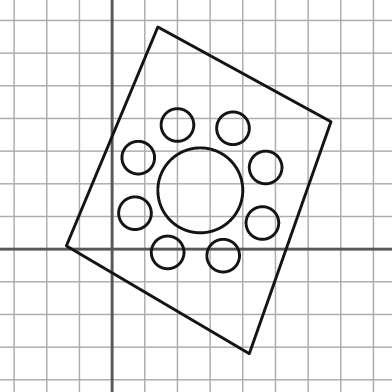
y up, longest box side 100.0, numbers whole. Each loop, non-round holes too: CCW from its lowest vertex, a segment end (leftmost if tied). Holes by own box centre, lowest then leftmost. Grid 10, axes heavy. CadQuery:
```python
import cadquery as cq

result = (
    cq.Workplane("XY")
    .moveTo(42.0, -32.0)
    .lineTo(67.0, 39.0)
    .lineTo(14.0, 68.0)
    .lineTo(-14.0, 1.0)
    .close()
    .moveTo(34.0, -2.0)
    .circle(5.0)
    .moveTo(17.0, -1.0)
    .circle(5.0)
    .moveTo(46.0, 8.0)
    .circle(5.0)
    .moveTo(7.0, 11.0)
    .circle(5.0)
    .moveTo(27.0, 18.0)
    .circle(13.0)
    .moveTo(47.0, 25.0)
    .circle(5.0)
    .moveTo(8.0, 28.0)
    .circle(5.0)
    .moveTo(37.0, 37.0)
    .circle(5.0)
    .moveTo(20.0, 38.0)
    .circle(5.0)
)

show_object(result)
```